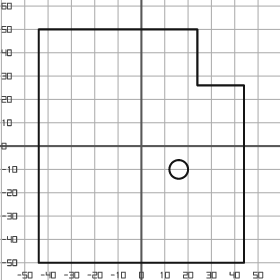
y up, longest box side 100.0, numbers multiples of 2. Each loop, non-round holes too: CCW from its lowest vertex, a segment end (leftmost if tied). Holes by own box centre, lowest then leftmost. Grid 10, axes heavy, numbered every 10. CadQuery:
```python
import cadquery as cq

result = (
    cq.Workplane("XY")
    .moveTo(-44.0, -50.0)
    .lineTo(44.0, -50.0)
    .lineTo(44.0, 26.0)
    .lineTo(24.0, 26.0)
    .lineTo(24.0, 50.0)
    .lineTo(-44.0, 50.0)
    .close()
    .moveTo(16.0, -10.0)
    .circle(4.0)
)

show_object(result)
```